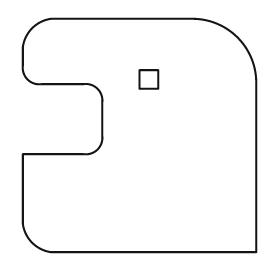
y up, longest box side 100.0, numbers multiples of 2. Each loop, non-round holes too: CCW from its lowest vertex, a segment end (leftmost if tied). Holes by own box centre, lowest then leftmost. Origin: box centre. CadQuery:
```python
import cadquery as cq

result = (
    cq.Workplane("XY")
    .moveTo(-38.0, -50.0)
    .lineTo(50.0, -50.0)
    .lineTo(50.0, 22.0)
    .threePointArc((42.0, 42.0), (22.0, 50.0))
    .lineTo(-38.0, 50.0)
    .threePointArc((-46.0, 46.0), (-50.0, 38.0))
    .lineTo(-50.0, 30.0)
    .threePointArc((-48.0, 24.0), (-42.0, 22.0))
    .lineTo(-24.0, 22.0)
    .threePointArc((-18.0, 20.0), (-16.0, 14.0))
    .lineTo(-16.0, 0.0)
    .threePointArc((-18.0, -6.0), (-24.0, -8.0))
    .lineTo(-50.0, -8.0)
    .lineTo(-50.0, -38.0)
    .threePointArc((-46.0, -46.0), (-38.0, -50.0))
    .close()
    .moveTo(0.0, 20.0)
    .lineTo(8.0, 20.0)
    .lineTo(8.0, 28.0)
    .lineTo(0.0, 28.0)
    .close()
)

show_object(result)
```